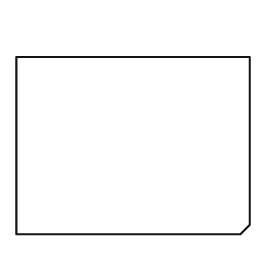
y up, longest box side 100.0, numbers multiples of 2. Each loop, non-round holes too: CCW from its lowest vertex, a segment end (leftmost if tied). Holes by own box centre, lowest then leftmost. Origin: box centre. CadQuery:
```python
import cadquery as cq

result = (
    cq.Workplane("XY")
    .moveTo(-50.0, -38.0)
    .lineTo(46.0, -38.0)
    .lineTo(50.0, -34.0)
    .lineTo(50.0, 38.0)
    .lineTo(-50.0, 38.0)
    .close()
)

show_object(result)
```